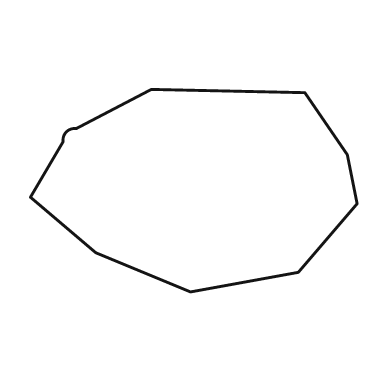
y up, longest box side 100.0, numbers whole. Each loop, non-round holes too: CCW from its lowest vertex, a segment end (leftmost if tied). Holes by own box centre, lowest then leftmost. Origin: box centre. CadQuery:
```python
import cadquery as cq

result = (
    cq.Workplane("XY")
    .moveTo(-1.0, -31.0)
    .lineTo(32.0, -25.0)
    .lineTo(50.0, -4.0)
    .lineTo(47.0, 11.0)
    .lineTo(34.0, 30.0)
    .lineTo(-13.0, 31.0)
    .lineTo(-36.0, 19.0)
    .threePointArc((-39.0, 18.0), (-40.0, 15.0))
    .lineTo(-50.0, -2.0)
    .lineTo(-30.0, -19.0)
    .close()
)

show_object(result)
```